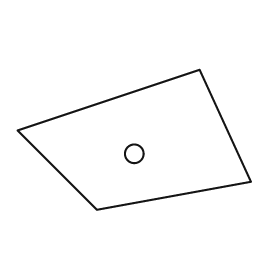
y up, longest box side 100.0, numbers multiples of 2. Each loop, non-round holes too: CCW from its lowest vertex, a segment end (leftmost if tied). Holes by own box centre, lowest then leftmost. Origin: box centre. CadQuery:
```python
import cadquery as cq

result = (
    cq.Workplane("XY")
    .moveTo(-16.0, -30.0)
    .lineTo(50.0, -18.0)
    .lineTo(28.0, 30.0)
    .lineTo(-50.0, 4.0)
    .close()
    .moveTo(0.0, -6.0)
    .circle(4.0)
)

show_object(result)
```